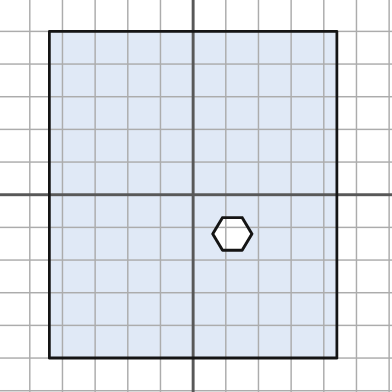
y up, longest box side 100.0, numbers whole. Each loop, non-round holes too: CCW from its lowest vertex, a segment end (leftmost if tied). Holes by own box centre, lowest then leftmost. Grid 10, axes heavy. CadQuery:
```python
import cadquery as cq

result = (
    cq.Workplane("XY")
    .moveTo(-44.0, -50.0)
    .lineTo(44.0, -50.0)
    .lineTo(44.0, 50.0)
    .lineTo(-44.0, 50.0)
    .close()
    .moveTo(9.0, -17.0)
    .lineTo(15.0, -17.0)
    .lineTo(18.0, -12.0)
    .lineTo(15.0, -7.0)
    .lineTo(9.0, -7.0)
    .lineTo(6.0, -12.0)
    .close()
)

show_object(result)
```